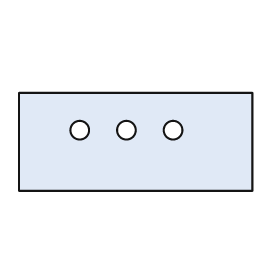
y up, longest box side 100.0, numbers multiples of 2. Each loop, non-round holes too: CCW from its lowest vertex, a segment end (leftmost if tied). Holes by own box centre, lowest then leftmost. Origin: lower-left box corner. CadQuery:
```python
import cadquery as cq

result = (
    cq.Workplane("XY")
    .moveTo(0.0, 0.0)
    .lineTo(100.0, 0.0)
    .lineTo(100.0, 42.0)
    .lineTo(0.0, 42.0)
    .close()
    .moveTo(26.0, 26.0)
    .circle(4.0)
    .moveTo(46.0, 26.0)
    .circle(4.0)
    .moveTo(66.0, 26.0)
    .circle(4.0)
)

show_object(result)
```